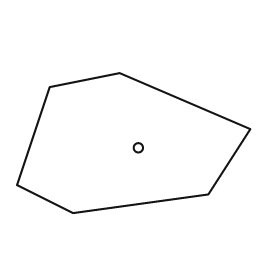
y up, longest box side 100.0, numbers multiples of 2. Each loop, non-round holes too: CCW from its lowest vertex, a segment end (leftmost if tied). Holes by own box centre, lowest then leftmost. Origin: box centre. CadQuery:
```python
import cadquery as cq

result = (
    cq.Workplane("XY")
    .moveTo(-26.0, -30.0)
    .lineTo(32.0, -22.0)
    .lineTo(50.0, 6.0)
    .lineTo(-6.0, 30.0)
    .lineTo(-36.0, 24.0)
    .lineTo(-50.0, -18.0)
    .close()
    .moveTo(2.0, -2.0)
    .circle(2.0)
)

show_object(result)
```